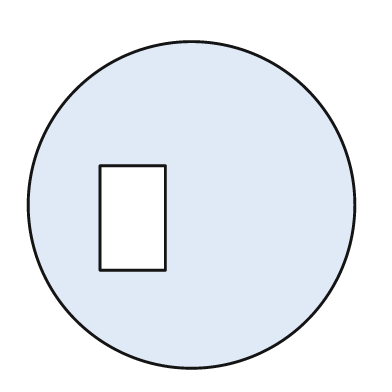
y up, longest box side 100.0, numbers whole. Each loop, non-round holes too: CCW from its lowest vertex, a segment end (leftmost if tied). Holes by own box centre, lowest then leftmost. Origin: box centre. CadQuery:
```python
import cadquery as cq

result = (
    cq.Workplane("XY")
    .moveTo(0.0, 0.0)
    .circle(50.0)
    .moveTo(-28.0, -20.0)
    .lineTo(-8.0, -20.0)
    .lineTo(-8.0, 12.0)
    .lineTo(-28.0, 12.0)
    .close()
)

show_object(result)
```